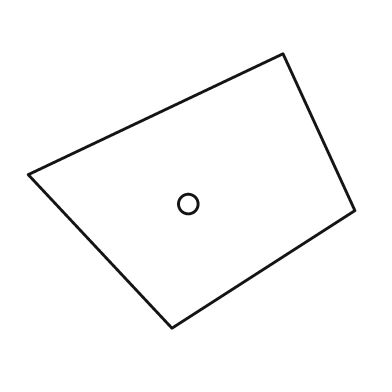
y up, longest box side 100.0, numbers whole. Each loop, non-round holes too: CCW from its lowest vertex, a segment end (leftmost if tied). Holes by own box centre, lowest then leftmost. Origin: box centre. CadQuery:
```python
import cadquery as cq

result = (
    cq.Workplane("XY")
    .moveTo(-6.0, -42.0)
    .lineTo(50.0, -6.0)
    .lineTo(28.0, 42.0)
    .lineTo(-50.0, 5.0)
    .close()
    .moveTo(-1.0, -4.0)
    .circle(3.0)
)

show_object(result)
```